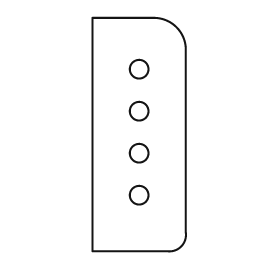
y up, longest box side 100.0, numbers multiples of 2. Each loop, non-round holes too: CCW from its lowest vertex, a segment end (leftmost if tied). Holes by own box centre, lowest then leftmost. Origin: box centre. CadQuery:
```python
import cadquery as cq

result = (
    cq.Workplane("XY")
    .moveTo(-20.0, -50.0)
    .lineTo(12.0, -50.0)
    .threePointArc((18.0, -48.0), (20.0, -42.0))
    .lineTo(20.0, 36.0)
    .threePointArc((16.0, 46.0), (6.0, 50.0))
    .lineTo(-20.0, 50.0)
    .close()
    .moveTo(0.0, -26.0)
    .circle(4.0)
    .moveTo(0.0, -8.0)
    .circle(4.0)
    .moveTo(0.0, 10.0)
    .circle(4.0)
    .moveTo(0.0, 28.0)
    .circle(4.0)
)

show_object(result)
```